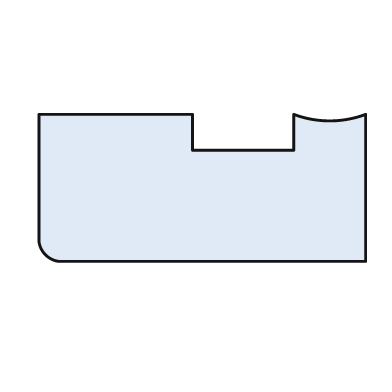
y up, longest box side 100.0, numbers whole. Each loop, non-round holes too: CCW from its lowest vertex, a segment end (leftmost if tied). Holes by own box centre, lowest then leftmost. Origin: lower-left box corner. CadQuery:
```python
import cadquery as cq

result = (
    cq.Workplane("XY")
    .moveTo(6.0, 0.0)
    .lineTo(100.0, 0.0)
    .lineTo(100.0, 45.0)
    .threePointArc((89.0, 43.0), (78.0, 45.0))
    .lineTo(78.0, 34.0)
    .lineTo(47.0, 34.0)
    .lineTo(47.0, 45.0)
    .lineTo(0.0, 45.0)
    .lineTo(0.0, 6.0)
    .threePointArc((2.0, 2.0), (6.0, 0.0))
    .close()
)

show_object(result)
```